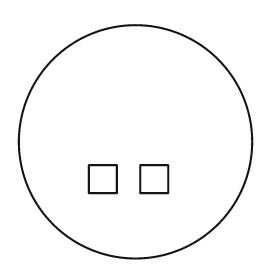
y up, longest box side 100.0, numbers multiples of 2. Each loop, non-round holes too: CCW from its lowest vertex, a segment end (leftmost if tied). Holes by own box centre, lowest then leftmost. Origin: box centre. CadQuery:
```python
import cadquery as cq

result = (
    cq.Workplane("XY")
    .moveTo(0.0, 0.0)
    .circle(50.0)
    .moveTo(-20.0, -22.0)
    .lineTo(-8.0, -22.0)
    .lineTo(-8.0, -10.0)
    .lineTo(-20.0, -10.0)
    .close()
    .moveTo(2.0, -22.0)
    .lineTo(14.0, -22.0)
    .lineTo(14.0, -10.0)
    .lineTo(2.0, -10.0)
    .close()
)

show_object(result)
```